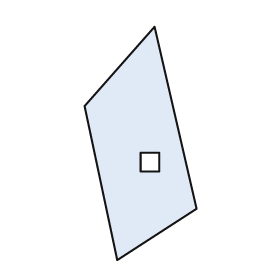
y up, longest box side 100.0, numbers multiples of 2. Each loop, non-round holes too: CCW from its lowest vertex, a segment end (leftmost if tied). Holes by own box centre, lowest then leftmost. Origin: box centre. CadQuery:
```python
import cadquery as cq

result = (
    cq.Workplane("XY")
    .moveTo(-10.0, -50.0)
    .lineTo(24.0, -28.0)
    .lineTo(6.0, 50.0)
    .lineTo(-24.0, 16.0)
    .close()
    .moveTo(0.0, -12.0)
    .lineTo(8.0, -12.0)
    .lineTo(8.0, -4.0)
    .lineTo(0.0, -4.0)
    .close()
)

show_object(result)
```